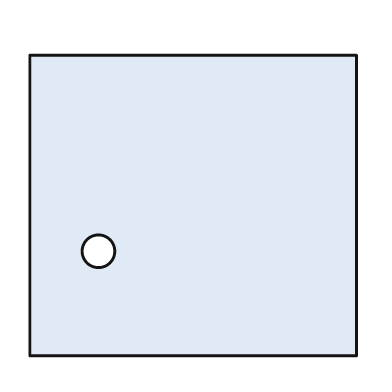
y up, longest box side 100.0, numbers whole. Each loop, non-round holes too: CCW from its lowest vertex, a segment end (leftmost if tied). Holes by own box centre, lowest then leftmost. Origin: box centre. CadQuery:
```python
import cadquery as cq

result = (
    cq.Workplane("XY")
    .moveTo(-50.0, -46.0)
    .lineTo(50.0, -46.0)
    .lineTo(50.0, 46.0)
    .lineTo(-50.0, 46.0)
    .close()
    .moveTo(-29.0, -14.0)
    .circle(5.0)
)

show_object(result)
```